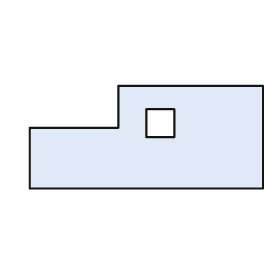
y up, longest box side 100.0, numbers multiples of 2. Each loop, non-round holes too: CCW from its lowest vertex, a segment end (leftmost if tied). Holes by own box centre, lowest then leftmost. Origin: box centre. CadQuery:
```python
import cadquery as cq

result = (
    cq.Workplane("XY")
    .moveTo(-50.0, -22.0)
    .lineTo(50.0, -22.0)
    .lineTo(50.0, 22.0)
    .lineTo(-12.0, 22.0)
    .lineTo(-12.0, 4.0)
    .lineTo(-50.0, 4.0)
    .close()
    .moveTo(0.0, 0.0)
    .lineTo(12.0, 0.0)
    .lineTo(12.0, 12.0)
    .lineTo(0.0, 12.0)
    .close()
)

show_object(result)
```